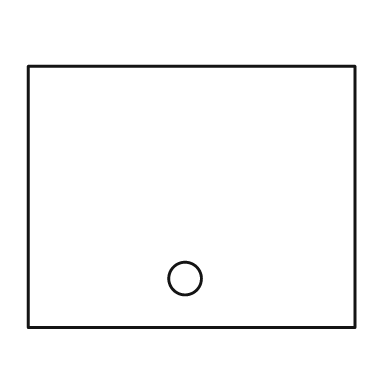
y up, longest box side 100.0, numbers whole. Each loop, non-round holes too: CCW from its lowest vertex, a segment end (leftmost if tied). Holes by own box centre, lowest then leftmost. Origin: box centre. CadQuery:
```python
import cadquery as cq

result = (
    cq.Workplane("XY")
    .moveTo(-50.0, -40.0)
    .lineTo(50.0, -40.0)
    .lineTo(50.0, 40.0)
    .lineTo(-50.0, 40.0)
    .close()
    .moveTo(-2.0, -25.0)
    .circle(5.0)
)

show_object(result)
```